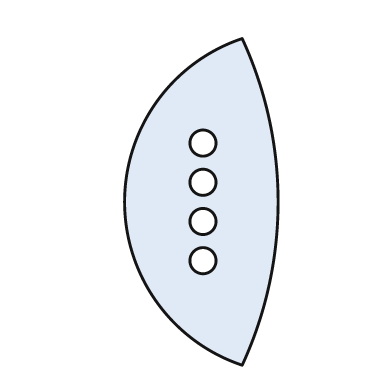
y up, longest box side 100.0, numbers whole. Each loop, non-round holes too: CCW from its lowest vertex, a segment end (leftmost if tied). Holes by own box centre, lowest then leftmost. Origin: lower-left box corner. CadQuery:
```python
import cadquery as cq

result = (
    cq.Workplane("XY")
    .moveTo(36.0, 0.0)
    .threePointArc((47.0, 50.0), (36.0, 100.0))
    .threePointArc((0.0, 50.0), (36.0, 0.0))
    .close()
    .moveTo(24.0, 32.0)
    .circle(4.0)
    .moveTo(24.0, 44.0)
    .circle(4.0)
    .moveTo(24.0, 56.0)
    .circle(4.0)
    .moveTo(24.0, 68.0)
    .circle(4.0)
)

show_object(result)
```